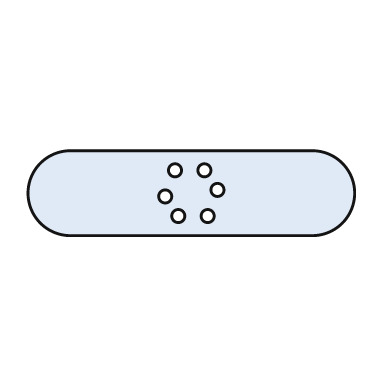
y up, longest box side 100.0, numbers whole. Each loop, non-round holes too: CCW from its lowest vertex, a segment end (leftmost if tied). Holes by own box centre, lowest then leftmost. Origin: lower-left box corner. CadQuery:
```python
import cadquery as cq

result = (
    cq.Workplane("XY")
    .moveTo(13.0, 0.0)
    .lineTo(87.0, 0.0)
    .threePointArc((100.0, 13.0), (87.0, 26.0))
    .lineTo(13.0, 26.0)
    .threePointArc((0.0, 13.0), (13.0, 0.0))
    .close()
    .moveTo(46.0, 6.0)
    .circle(2.0)
    .moveTo(55.0, 6.0)
    .circle(2.0)
    .moveTo(42.0, 12.0)
    .circle(2.0)
    .moveTo(58.0, 14.0)
    .circle(2.0)
    .moveTo(45.0, 20.0)
    .circle(2.0)
    .moveTo(54.0, 20.0)
    .circle(2.0)
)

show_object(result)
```